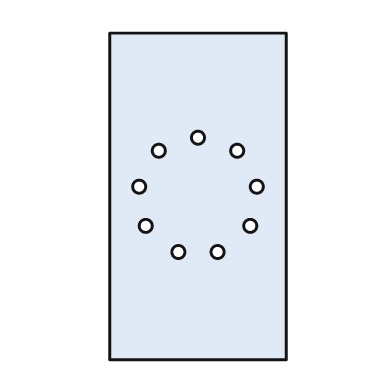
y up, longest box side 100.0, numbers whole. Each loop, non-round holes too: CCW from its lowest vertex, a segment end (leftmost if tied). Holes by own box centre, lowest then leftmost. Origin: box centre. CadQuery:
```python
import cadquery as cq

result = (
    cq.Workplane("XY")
    .moveTo(-27.0, -50.0)
    .lineTo(27.0, -50.0)
    .lineTo(27.0, 50.0)
    .lineTo(-27.0, 50.0)
    .close()
    .moveTo(-6.0, -17.0)
    .circle(2.0)
    .moveTo(6.0, -17.0)
    .circle(2.0)
    .moveTo(-16.0, -9.0)
    .circle(2.0)
    .moveTo(16.0, -9.0)
    .circle(2.0)
    .moveTo(-18.0, 3.0)
    .circle(2.0)
    .moveTo(18.0, 3.0)
    .circle(2.0)
    .moveTo(-12.0, 14.0)
    .circle(2.0)
    .moveTo(12.0, 14.0)
    .circle(2.0)
    .moveTo(0.0, 18.0)
    .circle(2.0)
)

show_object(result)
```